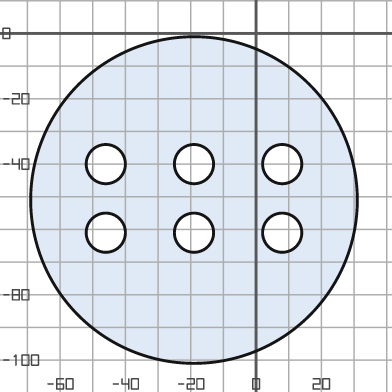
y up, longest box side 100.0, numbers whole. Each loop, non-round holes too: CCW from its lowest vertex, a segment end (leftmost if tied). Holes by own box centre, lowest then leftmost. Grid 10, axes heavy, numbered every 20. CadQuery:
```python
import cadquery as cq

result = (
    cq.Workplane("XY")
    .moveTo(-19.0, -51.0)
    .circle(50.0)
    .moveTo(-46.0, -61.0)
    .circle(6.0)
    .moveTo(-19.0, -61.0)
    .circle(6.0)
    .moveTo(8.0, -61.0)
    .circle(6.0)
    .moveTo(-46.0, -40.0)
    .circle(6.0)
    .moveTo(-19.0, -40.0)
    .circle(6.0)
    .moveTo(8.0, -40.0)
    .circle(6.0)
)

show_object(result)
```